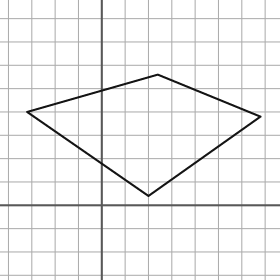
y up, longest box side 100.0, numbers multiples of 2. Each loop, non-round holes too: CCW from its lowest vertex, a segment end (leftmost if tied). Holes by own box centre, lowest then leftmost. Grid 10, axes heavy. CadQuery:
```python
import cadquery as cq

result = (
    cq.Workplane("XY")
    .moveTo(20.0, 4.0)
    .lineTo(68.0, 38.0)
    .lineTo(24.0, 56.0)
    .lineTo(-32.0, 40.0)
    .close()
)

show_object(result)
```